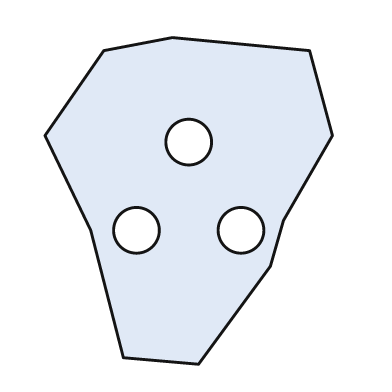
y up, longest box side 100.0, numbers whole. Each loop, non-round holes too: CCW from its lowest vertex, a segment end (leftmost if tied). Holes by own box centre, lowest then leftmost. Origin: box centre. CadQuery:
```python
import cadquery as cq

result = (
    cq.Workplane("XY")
    .moveTo(3.0, -50.0)
    .lineTo(25.0, -20.0)
    .lineTo(29.0, -6.0)
    .lineTo(44.0, 20.0)
    .lineTo(37.0, 46.0)
    .lineTo(-5.0, 50.0)
    .lineTo(-26.0, 46.0)
    .lineTo(-44.0, 20.0)
    .lineTo(-30.0, -9.0)
    .lineTo(-20.0, -48.0)
    .close()
    .moveTo(-16.0, -9.0)
    .circle(7.0)
    .moveTo(16.0, -9.0)
    .circle(7.0)
    .moveTo(0.0, 18.0)
    .circle(7.0)
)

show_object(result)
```